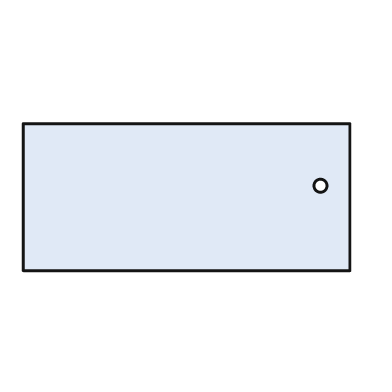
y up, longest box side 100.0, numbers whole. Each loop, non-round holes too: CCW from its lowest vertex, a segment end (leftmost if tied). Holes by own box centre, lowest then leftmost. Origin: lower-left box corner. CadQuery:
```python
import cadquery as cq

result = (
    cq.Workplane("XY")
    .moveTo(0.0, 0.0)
    .lineTo(100.0, 0.0)
    .lineTo(100.0, 45.0)
    .lineTo(0.0, 45.0)
    .close()
    .moveTo(91.0, 26.0)
    .circle(2.0)
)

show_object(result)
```